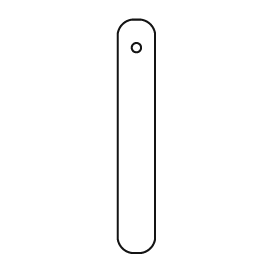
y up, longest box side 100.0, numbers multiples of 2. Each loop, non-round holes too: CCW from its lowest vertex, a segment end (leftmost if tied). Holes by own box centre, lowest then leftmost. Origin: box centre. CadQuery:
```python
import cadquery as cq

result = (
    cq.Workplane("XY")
    .moveTo(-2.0, -50.0)
    .lineTo(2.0, -50.0)
    .threePointArc((6.0, -48.0), (8.0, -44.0))
    .lineTo(8.0, 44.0)
    .threePointArc((6.0, 48.0), (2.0, 50.0))
    .lineTo(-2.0, 50.0)
    .threePointArc((-6.0, 48.0), (-8.0, 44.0))
    .lineTo(-8.0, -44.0)
    .threePointArc((-6.0, -48.0), (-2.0, -50.0))
    .close()
    .moveTo(0.0, 38.0)
    .circle(2.0)
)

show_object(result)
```